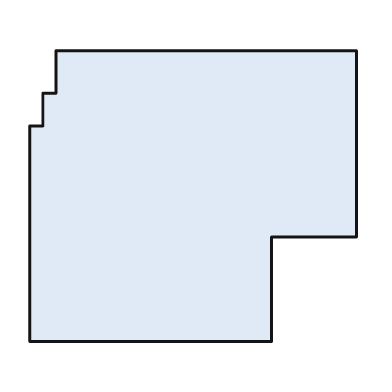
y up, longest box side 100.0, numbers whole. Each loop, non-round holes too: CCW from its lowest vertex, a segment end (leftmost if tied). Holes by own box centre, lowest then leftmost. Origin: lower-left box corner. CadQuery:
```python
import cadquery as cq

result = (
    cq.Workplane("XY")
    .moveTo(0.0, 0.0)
    .lineTo(74.0, 0.0)
    .lineTo(74.0, 32.0)
    .lineTo(100.0, 32.0)
    .lineTo(100.0, 89.0)
    .lineTo(8.0, 89.0)
    .lineTo(8.0, 76.0)
    .lineTo(4.0, 76.0)
    .lineTo(4.0, 66.0)
    .lineTo(0.0, 66.0)
    .close()
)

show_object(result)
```